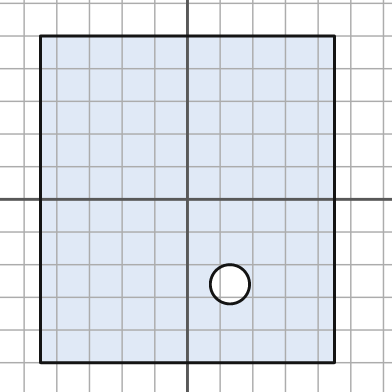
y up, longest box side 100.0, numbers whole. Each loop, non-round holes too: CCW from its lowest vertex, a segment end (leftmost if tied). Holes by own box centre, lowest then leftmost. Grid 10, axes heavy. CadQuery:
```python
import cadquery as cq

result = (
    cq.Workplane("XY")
    .moveTo(-45.0, -50.0)
    .lineTo(45.0, -50.0)
    .lineTo(45.0, 50.0)
    .lineTo(-45.0, 50.0)
    .close()
    .moveTo(13.0, -26.0)
    .circle(6.0)
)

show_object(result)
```